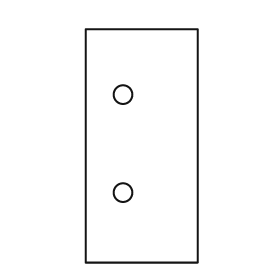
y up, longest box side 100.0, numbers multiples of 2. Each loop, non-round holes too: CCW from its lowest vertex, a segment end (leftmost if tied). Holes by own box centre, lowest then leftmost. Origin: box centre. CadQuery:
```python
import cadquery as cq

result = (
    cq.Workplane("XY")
    .moveTo(-24.0, -50.0)
    .lineTo(24.0, -50.0)
    .lineTo(24.0, 50.0)
    .lineTo(-24.0, 50.0)
    .close()
    .moveTo(-8.0, -20.0)
    .circle(4.0)
    .moveTo(-8.0, 22.0)
    .circle(4.0)
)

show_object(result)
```